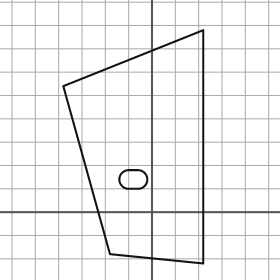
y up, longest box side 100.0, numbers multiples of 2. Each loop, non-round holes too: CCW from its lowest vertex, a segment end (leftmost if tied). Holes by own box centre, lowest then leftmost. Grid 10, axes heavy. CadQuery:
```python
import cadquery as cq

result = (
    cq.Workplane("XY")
    .moveTo(22.0, -22.0)
    .lineTo(22.0, 78.0)
    .lineTo(-38.0, 54.0)
    .lineTo(-18.0, -18.0)
    .close()
    .moveTo(-10.0, 10.0)
    .lineTo(-6.0, 10.0)
    .threePointArc((-2.0, 14.0), (-6.0, 18.0))
    .lineTo(-10.0, 18.0)
    .threePointArc((-14.0, 14.0), (-10.0, 10.0))
    .close()
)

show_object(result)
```